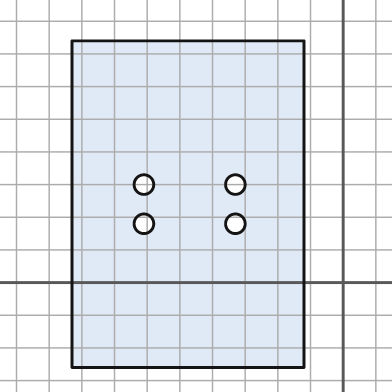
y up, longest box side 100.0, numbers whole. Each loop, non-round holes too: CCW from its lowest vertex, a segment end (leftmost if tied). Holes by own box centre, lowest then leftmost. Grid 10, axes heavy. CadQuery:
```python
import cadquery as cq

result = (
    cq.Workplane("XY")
    .moveTo(-83.0, -26.0)
    .lineTo(-12.0, -26.0)
    .lineTo(-12.0, 74.0)
    .lineTo(-83.0, 74.0)
    .close()
    .moveTo(-61.0, 18.0)
    .circle(3.0)
    .moveTo(-33.0, 18.0)
    .circle(3.0)
    .moveTo(-61.0, 30.0)
    .circle(3.0)
    .moveTo(-33.0, 30.0)
    .circle(3.0)
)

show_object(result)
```